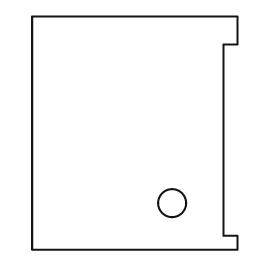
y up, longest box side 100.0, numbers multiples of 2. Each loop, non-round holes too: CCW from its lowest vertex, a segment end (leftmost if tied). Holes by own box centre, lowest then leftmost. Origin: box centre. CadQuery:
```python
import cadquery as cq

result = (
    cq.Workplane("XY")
    .moveTo(-44.0, -50.0)
    .lineTo(44.0, -50.0)
    .lineTo(44.0, -44.0)
    .lineTo(38.0, -44.0)
    .lineTo(38.0, 38.0)
    .lineTo(44.0, 38.0)
    .lineTo(44.0, 50.0)
    .lineTo(-44.0, 50.0)
    .close()
    .moveTo(16.0, -30.0)
    .circle(6.0)
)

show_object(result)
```